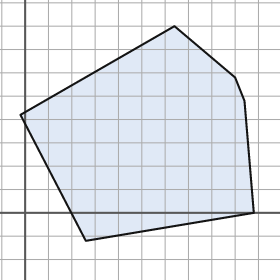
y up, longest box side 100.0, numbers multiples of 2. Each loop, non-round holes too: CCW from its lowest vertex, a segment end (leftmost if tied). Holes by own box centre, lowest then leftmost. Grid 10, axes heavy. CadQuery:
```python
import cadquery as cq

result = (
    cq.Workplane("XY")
    .moveTo(26.0, -12.0)
    .lineTo(98.0, 0.0)
    .lineTo(94.0, 48.0)
    .lineTo(90.0, 58.0)
    .lineTo(64.0, 80.0)
    .lineTo(-2.0, 42.0)
    .close()
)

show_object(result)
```